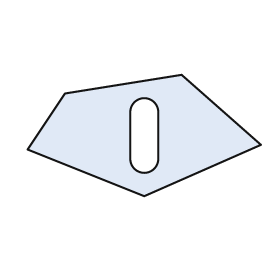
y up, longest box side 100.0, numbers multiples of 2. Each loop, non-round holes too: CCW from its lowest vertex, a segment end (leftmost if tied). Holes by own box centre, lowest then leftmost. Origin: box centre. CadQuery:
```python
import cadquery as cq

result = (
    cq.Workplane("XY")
    .moveTo(0.0, -26.0)
    .lineTo(50.0, -4.0)
    .lineTo(16.0, 26.0)
    .lineTo(-34.0, 18.0)
    .lineTo(-50.0, -6.0)
    .close()
    .moveTo(-6.0, -10.0)
    .threePointArc((0.0, -16.0), (6.0, -10.0))
    .lineTo(6.0, 10.0)
    .threePointArc((0.0, 16.0), (-6.0, 10.0))
    .close()
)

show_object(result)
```